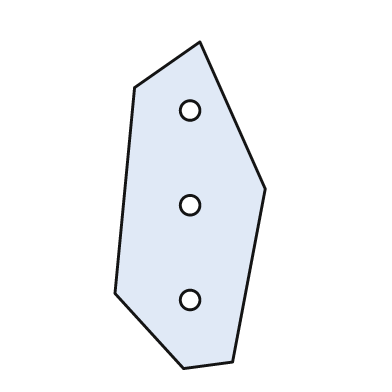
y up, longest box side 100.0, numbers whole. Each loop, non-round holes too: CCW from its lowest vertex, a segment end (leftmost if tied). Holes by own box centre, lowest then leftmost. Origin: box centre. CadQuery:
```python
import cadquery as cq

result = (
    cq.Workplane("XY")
    .moveTo(-2.0, -50.0)
    .lineTo(13.0, -48.0)
    .lineTo(23.0, 5.0)
    .lineTo(3.0, 50.0)
    .lineTo(-17.0, 36.0)
    .lineTo(-23.0, -27.0)
    .close()
    .moveTo(0.0, -29.0)
    .circle(3.0)
    .moveTo(0.0, 0.0)
    .circle(3.0)
    .moveTo(0.0, 29.0)
    .circle(3.0)
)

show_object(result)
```